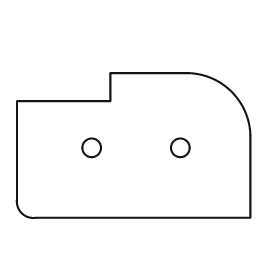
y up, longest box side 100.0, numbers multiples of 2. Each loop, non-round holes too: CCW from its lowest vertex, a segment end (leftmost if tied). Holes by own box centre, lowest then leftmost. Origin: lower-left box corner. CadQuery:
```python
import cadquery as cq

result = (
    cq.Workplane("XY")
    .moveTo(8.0, 0.0)
    .lineTo(100.0, 0.0)
    .lineTo(100.0, 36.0)
    .threePointArc((92.0, 54.0), (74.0, 62.0))
    .lineTo(40.0, 62.0)
    .lineTo(40.0, 50.0)
    .lineTo(0.0, 50.0)
    .lineTo(0.0, 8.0)
    .threePointArc((2.0, 2.0), (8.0, 0.0))
    .close()
    .moveTo(32.0, 30.0)
    .circle(4.0)
    .moveTo(70.0, 30.0)
    .circle(4.0)
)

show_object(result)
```